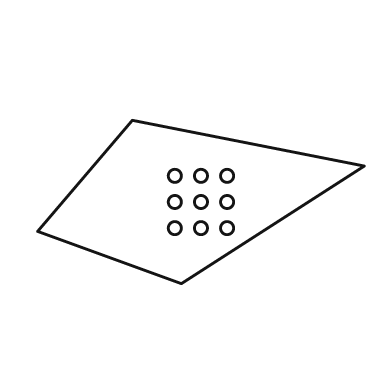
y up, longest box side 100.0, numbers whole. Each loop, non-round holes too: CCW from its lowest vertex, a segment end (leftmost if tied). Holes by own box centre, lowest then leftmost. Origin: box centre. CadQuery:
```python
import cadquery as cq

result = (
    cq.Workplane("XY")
    .moveTo(-6.0, -25.0)
    .lineTo(50.0, 11.0)
    .lineTo(-21.0, 25.0)
    .lineTo(-50.0, -9.0)
    .close()
    .moveTo(-8.0, -8.0)
    .circle(2.0)
    .moveTo(0.0, -8.0)
    .circle(2.0)
    .moveTo(8.0, -8.0)
    .circle(2.0)
    .moveTo(-8.0, 0.0)
    .circle(2.0)
    .moveTo(0.0, 0.0)
    .circle(2.0)
    .moveTo(8.0, 0.0)
    .circle(2.0)
    .moveTo(-8.0, 8.0)
    .circle(2.0)
    .moveTo(0.0, 8.0)
    .circle(2.0)
    .moveTo(8.0, 8.0)
    .circle(2.0)
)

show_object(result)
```